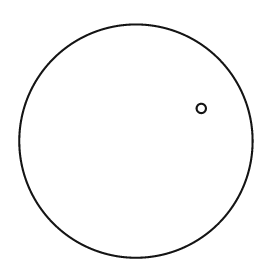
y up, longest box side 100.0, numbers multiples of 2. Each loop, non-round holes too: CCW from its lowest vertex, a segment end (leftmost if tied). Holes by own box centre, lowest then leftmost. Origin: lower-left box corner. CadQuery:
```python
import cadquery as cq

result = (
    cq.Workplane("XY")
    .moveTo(50.0, 50.0)
    .circle(50.0)
    .moveTo(78.0, 64.0)
    .circle(2.0)
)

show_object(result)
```